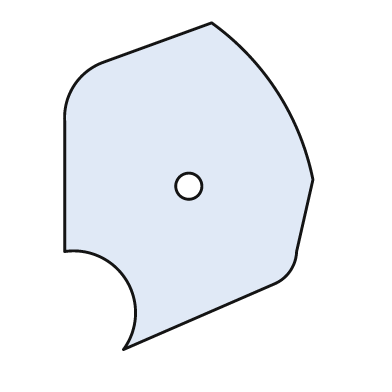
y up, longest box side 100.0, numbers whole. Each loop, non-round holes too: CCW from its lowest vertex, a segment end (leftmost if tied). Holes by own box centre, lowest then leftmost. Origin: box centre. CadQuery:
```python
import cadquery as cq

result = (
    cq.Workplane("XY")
    .moveTo(-20.0, -50.0)
    .lineTo(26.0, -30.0)
    .threePointArc((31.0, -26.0), (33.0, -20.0))
    .lineTo(38.0, 2.0)
    .threePointArc((27.0, 29.0), (7.0, 50.0))
    .lineTo(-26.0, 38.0)
    .threePointArc((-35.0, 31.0), (-38.0, 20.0))
    .lineTo(-38.0, -20.0)
    .threePointArc((-19.0, -29.0), (-20.0, -50.0))
    .close()
    .moveTo(0.0, 0.0)
    .circle(4.0)
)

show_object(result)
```